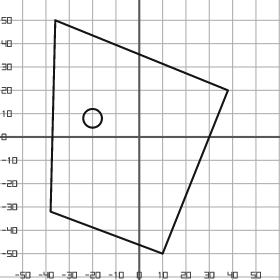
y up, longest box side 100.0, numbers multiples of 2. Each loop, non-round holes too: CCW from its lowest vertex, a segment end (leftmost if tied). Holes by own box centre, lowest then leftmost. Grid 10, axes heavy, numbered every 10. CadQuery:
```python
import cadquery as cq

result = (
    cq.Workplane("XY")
    .moveTo(10.0, -50.0)
    .lineTo(38.0, 20.0)
    .lineTo(-36.0, 50.0)
    .lineTo(-38.0, -32.0)
    .close()
    .moveTo(-20.0, 8.0)
    .circle(4.0)
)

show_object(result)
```